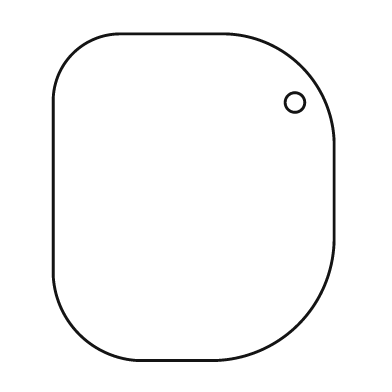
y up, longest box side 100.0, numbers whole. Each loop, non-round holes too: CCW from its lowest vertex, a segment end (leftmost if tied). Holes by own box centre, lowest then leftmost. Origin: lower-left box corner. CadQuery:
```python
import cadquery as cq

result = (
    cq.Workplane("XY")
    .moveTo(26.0, 0.0)
    .lineTo(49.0, 0.0)
    .threePointArc((75.0, 11.0), (86.0, 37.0))
    .lineTo(86.0, 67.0)
    .threePointArc((76.0, 90.0), (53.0, 100.0))
    .lineTo(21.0, 100.0)
    .threePointArc((6.0, 94.0), (0.0, 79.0))
    .lineTo(0.0, 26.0)
    .threePointArc((8.0, 8.0), (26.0, 0.0))
    .close()
    .moveTo(74.0, 79.0)
    .circle(3.0)
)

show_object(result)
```